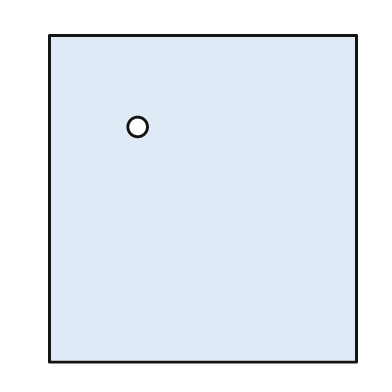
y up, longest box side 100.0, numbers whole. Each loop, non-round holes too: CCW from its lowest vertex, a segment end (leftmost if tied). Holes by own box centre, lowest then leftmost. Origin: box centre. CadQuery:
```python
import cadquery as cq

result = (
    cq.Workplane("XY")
    .moveTo(-47.0, -50.0)
    .lineTo(47.0, -50.0)
    .lineTo(47.0, 50.0)
    .lineTo(-47.0, 50.0)
    .close()
    .moveTo(-20.0, 22.0)
    .circle(3.0)
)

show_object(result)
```